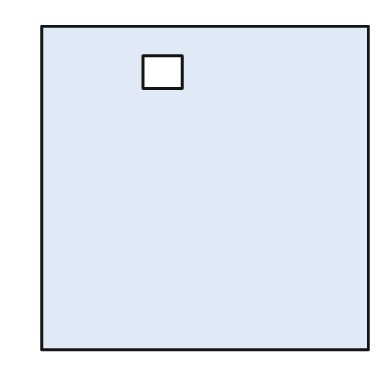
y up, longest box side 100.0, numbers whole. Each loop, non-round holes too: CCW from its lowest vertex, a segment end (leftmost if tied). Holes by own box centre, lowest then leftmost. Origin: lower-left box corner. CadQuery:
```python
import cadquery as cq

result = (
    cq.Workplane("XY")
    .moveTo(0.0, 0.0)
    .lineTo(100.0, 0.0)
    .lineTo(100.0, 99.0)
    .lineTo(0.0, 99.0)
    .close()
    .moveTo(31.0, 80.0)
    .lineTo(43.0, 80.0)
    .lineTo(43.0, 90.0)
    .lineTo(31.0, 90.0)
    .close()
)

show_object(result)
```